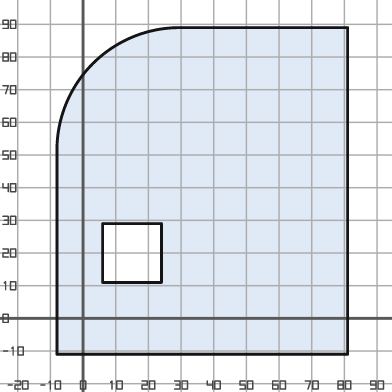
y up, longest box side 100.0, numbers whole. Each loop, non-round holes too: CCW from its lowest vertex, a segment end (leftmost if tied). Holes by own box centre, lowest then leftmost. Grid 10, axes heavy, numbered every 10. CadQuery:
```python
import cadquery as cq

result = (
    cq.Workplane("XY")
    .moveTo(-8.0, -11.0)
    .lineTo(81.0, -11.0)
    .lineTo(81.0, 89.0)
    .lineTo(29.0, 89.0)
    .threePointArc((3.0, 78.0), (-8.0, 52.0))
    .close()
    .moveTo(6.0, 11.0)
    .lineTo(24.0, 11.0)
    .lineTo(24.0, 29.0)
    .lineTo(6.0, 29.0)
    .close()
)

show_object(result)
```